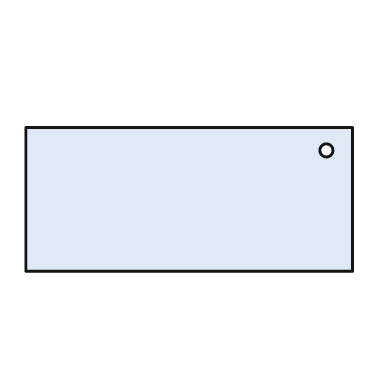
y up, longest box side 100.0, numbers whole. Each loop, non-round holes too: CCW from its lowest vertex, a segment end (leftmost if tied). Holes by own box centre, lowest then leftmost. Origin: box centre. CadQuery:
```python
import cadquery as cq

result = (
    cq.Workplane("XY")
    .moveTo(-50.0, -22.0)
    .lineTo(50.0, -22.0)
    .lineTo(50.0, 22.0)
    .lineTo(-50.0, 22.0)
    .close()
    .moveTo(42.0, 15.0)
    .circle(2.0)
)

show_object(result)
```